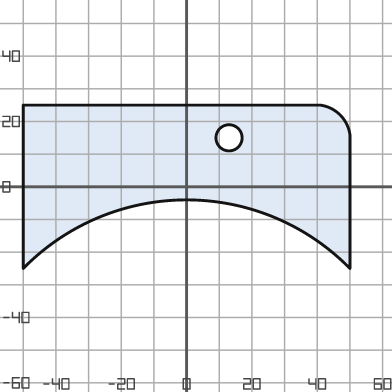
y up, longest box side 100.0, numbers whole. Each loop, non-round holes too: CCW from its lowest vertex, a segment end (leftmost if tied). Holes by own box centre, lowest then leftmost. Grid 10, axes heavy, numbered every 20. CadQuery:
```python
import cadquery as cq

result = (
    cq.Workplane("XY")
    .moveTo(-50.0, -25.0)
    .threePointArc((0.0, -4.0), (50.0, -25.0))
    .lineTo(50.0, 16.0)
    .threePointArc((47.0, 22.0), (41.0, 25.0))
    .lineTo(-50.0, 25.0)
    .close()
    .moveTo(13.0, 15.0)
    .circle(4.0)
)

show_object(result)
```